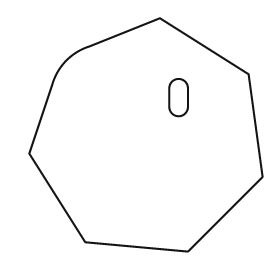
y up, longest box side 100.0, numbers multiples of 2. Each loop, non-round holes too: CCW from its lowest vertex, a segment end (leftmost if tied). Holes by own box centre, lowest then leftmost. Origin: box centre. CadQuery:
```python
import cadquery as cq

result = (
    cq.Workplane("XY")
    .moveTo(18.0, -50.0)
    .lineTo(50.0, -18.0)
    .lineTo(44.0, 26.0)
    .lineTo(6.0, 50.0)
    .lineTo(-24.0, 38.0)
    .threePointArc((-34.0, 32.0), (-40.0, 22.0))
    .lineTo(-50.0, -8.0)
    .lineTo(-26.0, -46.0)
    .close()
    .moveTo(10.0, 12.0)
    .threePointArc((14.0, 8.0), (18.0, 12.0))
    .lineTo(18.0, 20.0)
    .threePointArc((14.0, 24.0), (10.0, 20.0))
    .close()
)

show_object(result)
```